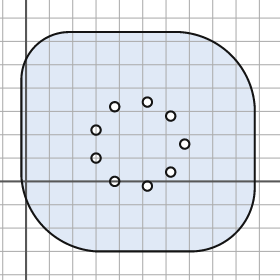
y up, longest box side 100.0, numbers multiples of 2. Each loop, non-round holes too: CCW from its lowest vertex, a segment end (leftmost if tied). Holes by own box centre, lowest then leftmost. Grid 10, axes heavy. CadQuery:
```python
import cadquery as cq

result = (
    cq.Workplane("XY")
    .moveTo(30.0, -30.0)
    .lineTo(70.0, -30.0)
    .threePointArc((90.0, -22.0), (98.0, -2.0))
    .lineTo(98.0, 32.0)
    .threePointArc((88.0, 54.0), (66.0, 64.0))
    .lineTo(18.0, 64.0)
    .threePointArc((4.0, 58.0), (-2.0, 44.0))
    .lineTo(-2.0, 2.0)
    .threePointArc((8.0, -20.0), (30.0, -30.0))
    .close()
    .moveTo(52.0, -2.0)
    .circle(2.0)
    .moveTo(38.0, 0.0)
    .circle(2.0)
    .moveTo(62.0, 4.0)
    .circle(2.0)
    .moveTo(30.0, 10.0)
    .circle(2.0)
    .moveTo(68.0, 16.0)
    .circle(2.0)
    .moveTo(30.0, 22.0)
    .circle(2.0)
    .moveTo(62.0, 28.0)
    .circle(2.0)
    .moveTo(38.0, 32.0)
    .circle(2.0)
    .moveTo(52.0, 34.0)
    .circle(2.0)
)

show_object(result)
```